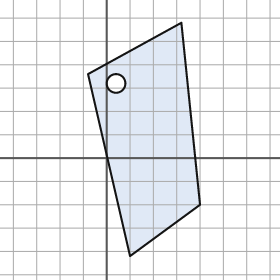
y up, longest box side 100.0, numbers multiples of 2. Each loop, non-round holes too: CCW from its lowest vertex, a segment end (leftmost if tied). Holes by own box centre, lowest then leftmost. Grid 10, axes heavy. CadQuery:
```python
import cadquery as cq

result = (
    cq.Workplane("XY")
    .moveTo(10.0, -42.0)
    .lineTo(40.0, -20.0)
    .lineTo(32.0, 58.0)
    .lineTo(-8.0, 36.0)
    .close()
    .moveTo(4.0, 32.0)
    .circle(4.0)
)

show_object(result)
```